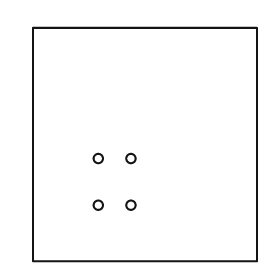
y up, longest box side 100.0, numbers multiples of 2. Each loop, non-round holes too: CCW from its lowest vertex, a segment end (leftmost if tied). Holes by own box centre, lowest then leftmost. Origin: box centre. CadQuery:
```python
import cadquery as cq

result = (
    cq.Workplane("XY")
    .moveTo(-48.0, -50.0)
    .lineTo(48.0, -50.0)
    .lineTo(48.0, 50.0)
    .lineTo(-48.0, 50.0)
    .close()
    .moveTo(-20.0, -26.0)
    .circle(2.0)
    .moveTo(-6.0, -26.0)
    .circle(2.0)
    .moveTo(-20.0, -6.0)
    .circle(2.0)
    .moveTo(-6.0, -6.0)
    .circle(2.0)
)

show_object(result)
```